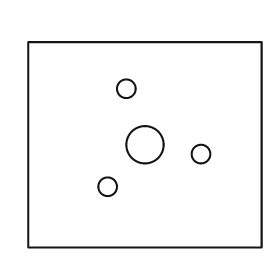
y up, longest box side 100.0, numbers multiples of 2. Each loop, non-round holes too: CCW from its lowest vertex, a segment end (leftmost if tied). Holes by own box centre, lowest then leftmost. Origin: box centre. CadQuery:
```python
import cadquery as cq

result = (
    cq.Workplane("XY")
    .moveTo(-50.0, -44.0)
    .lineTo(50.0, -44.0)
    .lineTo(50.0, 44.0)
    .lineTo(-50.0, 44.0)
    .close()
    .moveTo(-16.0, -18.0)
    .circle(4.0)
    .moveTo(24.0, -4.0)
    .circle(4.0)
    .moveTo(0.0, 0.0)
    .circle(8.0)
    .moveTo(-8.0, 24.0)
    .circle(4.0)
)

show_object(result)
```